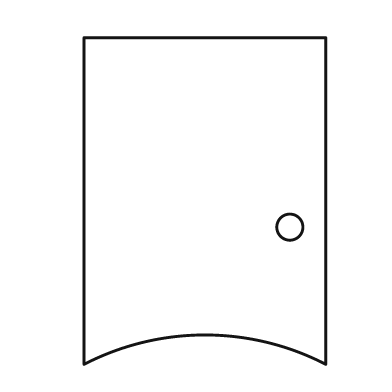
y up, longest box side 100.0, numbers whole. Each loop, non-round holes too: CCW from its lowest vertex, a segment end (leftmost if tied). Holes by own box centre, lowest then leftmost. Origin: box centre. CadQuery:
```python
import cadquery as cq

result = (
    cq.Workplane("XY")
    .moveTo(-37.0, -50.0)
    .threePointArc((0.0, -41.0), (37.0, -50.0))
    .lineTo(37.0, 50.0)
    .lineTo(-37.0, 50.0)
    .close()
    .moveTo(26.0, -8.0)
    .circle(4.0)
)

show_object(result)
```